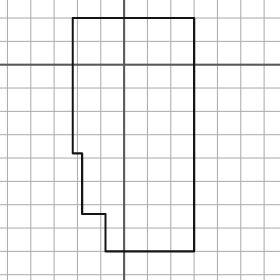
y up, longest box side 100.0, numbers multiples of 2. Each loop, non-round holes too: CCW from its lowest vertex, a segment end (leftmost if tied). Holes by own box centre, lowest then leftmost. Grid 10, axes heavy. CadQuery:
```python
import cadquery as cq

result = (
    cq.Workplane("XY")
    .moveTo(-8.0, -80.0)
    .lineTo(30.0, -80.0)
    .lineTo(30.0, 20.0)
    .lineTo(-22.0, 20.0)
    .lineTo(-22.0, -38.0)
    .lineTo(-18.0, -38.0)
    .lineTo(-18.0, -64.0)
    .lineTo(-8.0, -64.0)
    .close()
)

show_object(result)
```